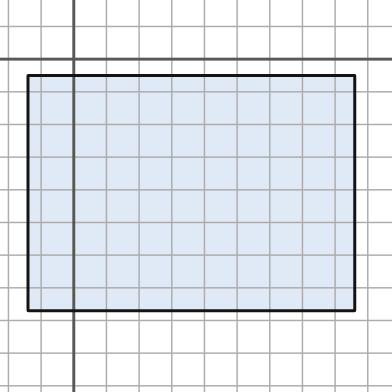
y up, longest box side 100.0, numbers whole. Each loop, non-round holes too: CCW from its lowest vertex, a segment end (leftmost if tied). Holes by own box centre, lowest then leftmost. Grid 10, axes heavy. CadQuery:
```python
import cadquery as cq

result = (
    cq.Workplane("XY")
    .moveTo(-14.0, -77.0)
    .lineTo(86.0, -77.0)
    .lineTo(86.0, -5.0)
    .lineTo(-14.0, -5.0)
    .close()
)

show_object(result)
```